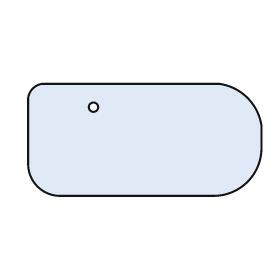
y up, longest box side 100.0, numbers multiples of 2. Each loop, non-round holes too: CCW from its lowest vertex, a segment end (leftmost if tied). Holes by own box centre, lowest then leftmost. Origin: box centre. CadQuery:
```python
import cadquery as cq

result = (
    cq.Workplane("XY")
    .moveTo(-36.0, -24.0)
    .lineTo(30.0, -24.0)
    .threePointArc((44.0, -18.0), (50.0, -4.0))
    .lineTo(50.0, 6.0)
    .threePointArc((44.0, 18.0), (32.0, 24.0))
    .lineTo(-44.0, 24.0)
    .threePointArc((-48.0, 22.0), (-50.0, 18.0))
    .lineTo(-50.0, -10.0)
    .threePointArc((-46.0, -20.0), (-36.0, -24.0))
    .close()
    .moveTo(-22.0, 14.0)
    .circle(2.0)
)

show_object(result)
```